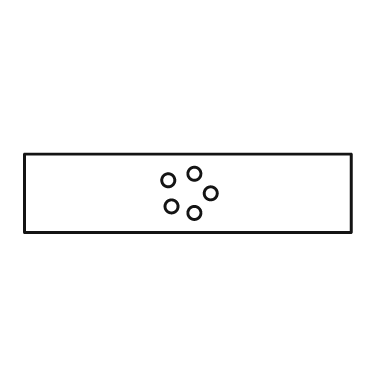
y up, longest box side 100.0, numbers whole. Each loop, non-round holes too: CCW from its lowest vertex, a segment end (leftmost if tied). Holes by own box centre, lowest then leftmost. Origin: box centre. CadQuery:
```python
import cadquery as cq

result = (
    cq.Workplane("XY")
    .moveTo(-50.0, -12.0)
    .lineTo(50.0, -12.0)
    .lineTo(50.0, 12.0)
    .lineTo(-50.0, 12.0)
    .close()
    .moveTo(2.0, -6.0)
    .circle(2.0)
    .moveTo(-5.0, -4.0)
    .circle(2.0)
    .moveTo(7.0, 0.0)
    .circle(2.0)
    .moveTo(-6.0, 4.0)
    .circle(2.0)
    .moveTo(2.0, 6.0)
    .circle(2.0)
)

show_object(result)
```